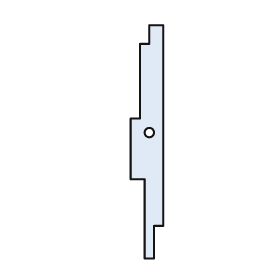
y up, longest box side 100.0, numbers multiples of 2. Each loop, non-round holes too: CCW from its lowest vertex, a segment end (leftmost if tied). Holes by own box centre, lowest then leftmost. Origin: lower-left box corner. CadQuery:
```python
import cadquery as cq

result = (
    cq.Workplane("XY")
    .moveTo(6.0, 0.0)
    .lineTo(10.0, 0.0)
    .lineTo(10.0, 14.0)
    .lineTo(14.0, 14.0)
    .lineTo(14.0, 100.0)
    .lineTo(8.0, 100.0)
    .lineTo(8.0, 92.0)
    .lineTo(4.0, 92.0)
    .lineTo(4.0, 60.0)
    .lineTo(0.0, 60.0)
    .lineTo(0.0, 34.0)
    .lineTo(6.0, 34.0)
    .close()
    .moveTo(8.0, 54.0)
    .circle(2.0)
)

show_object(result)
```